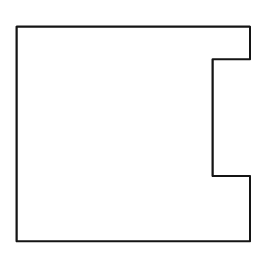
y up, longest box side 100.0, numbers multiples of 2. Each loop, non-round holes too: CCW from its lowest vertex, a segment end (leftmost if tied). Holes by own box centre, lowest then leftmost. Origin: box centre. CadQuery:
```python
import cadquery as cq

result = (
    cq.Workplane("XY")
    .moveTo(-50.0, -46.0)
    .lineTo(50.0, -46.0)
    .lineTo(50.0, -18.0)
    .lineTo(34.0, -18.0)
    .lineTo(34.0, 32.0)
    .lineTo(50.0, 32.0)
    .lineTo(50.0, 46.0)
    .lineTo(-50.0, 46.0)
    .close()
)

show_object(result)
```